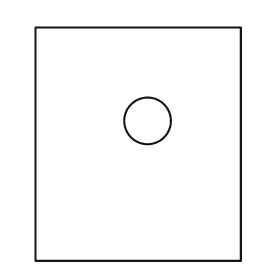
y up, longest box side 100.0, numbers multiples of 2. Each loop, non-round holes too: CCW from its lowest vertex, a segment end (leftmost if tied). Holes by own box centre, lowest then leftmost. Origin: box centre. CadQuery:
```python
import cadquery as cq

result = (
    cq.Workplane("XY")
    .moveTo(-44.0, -50.0)
    .lineTo(44.0, -50.0)
    .lineTo(44.0, 50.0)
    .lineTo(-44.0, 50.0)
    .close()
    .moveTo(4.0, 10.0)
    .circle(10.0)
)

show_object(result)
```